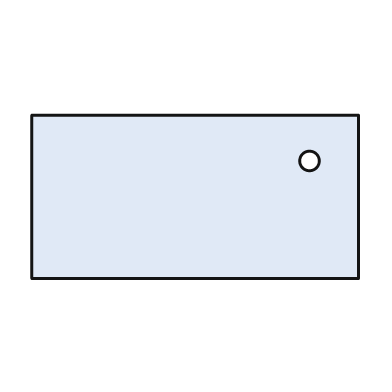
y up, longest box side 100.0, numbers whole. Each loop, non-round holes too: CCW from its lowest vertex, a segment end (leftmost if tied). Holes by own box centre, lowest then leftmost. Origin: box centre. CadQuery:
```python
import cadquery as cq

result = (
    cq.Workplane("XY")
    .moveTo(-50.0, -25.0)
    .lineTo(50.0, -25.0)
    .lineTo(50.0, 25.0)
    .lineTo(-50.0, 25.0)
    .close()
    .moveTo(35.0, 11.0)
    .circle(3.0)
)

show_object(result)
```